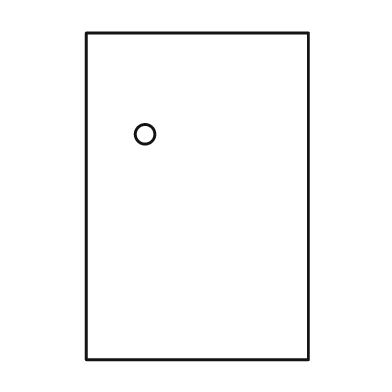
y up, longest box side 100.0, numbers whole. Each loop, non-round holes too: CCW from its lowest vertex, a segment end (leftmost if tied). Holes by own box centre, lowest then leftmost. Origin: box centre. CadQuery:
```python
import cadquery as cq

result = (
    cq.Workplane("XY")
    .moveTo(-34.0, -50.0)
    .lineTo(34.0, -50.0)
    .lineTo(34.0, 50.0)
    .lineTo(-34.0, 50.0)
    .close()
    .moveTo(-16.0, 19.0)
    .circle(3.0)
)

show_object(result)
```